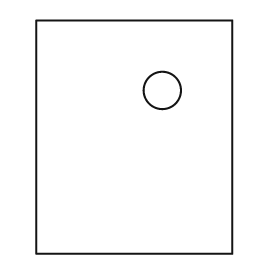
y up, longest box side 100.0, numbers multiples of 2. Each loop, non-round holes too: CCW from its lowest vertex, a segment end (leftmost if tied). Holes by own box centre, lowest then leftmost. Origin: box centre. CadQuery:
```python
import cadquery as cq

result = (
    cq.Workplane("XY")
    .moveTo(-42.0, -50.0)
    .lineTo(42.0, -50.0)
    .lineTo(42.0, 50.0)
    .lineTo(-42.0, 50.0)
    .close()
    .moveTo(12.0, 20.0)
    .circle(8.0)
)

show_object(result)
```